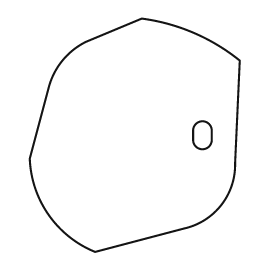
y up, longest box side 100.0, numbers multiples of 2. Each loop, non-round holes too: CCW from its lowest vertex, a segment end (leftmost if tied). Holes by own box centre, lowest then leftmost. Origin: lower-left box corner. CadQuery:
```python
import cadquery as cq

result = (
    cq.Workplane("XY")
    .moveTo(28.0, 0.0)
    .lineTo(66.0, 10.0)
    .threePointArc((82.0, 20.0), (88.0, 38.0))
    .lineTo(90.0, 82.0)
    .threePointArc((70.0, 94.0), (48.0, 100.0))
    .lineTo(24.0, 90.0)
    .threePointArc((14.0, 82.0), (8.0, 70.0))
    .lineTo(0.0, 40.0)
    .threePointArc((8.0, 16.0), (28.0, 0.0))
    .close()
    .moveTo(70.0, 48.0)
    .threePointArc((74.0, 44.0), (78.0, 48.0))
    .lineTo(78.0, 52.0)
    .threePointArc((74.0, 56.0), (70.0, 52.0))
    .close()
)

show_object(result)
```